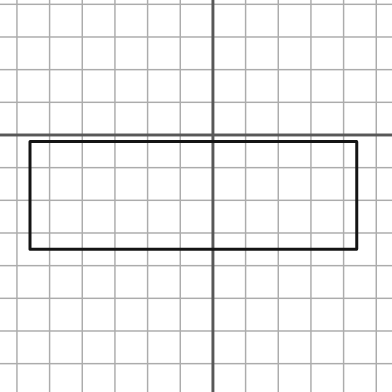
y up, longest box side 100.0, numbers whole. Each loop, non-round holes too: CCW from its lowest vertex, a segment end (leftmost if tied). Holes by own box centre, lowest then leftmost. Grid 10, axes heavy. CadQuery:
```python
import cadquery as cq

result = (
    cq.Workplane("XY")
    .moveTo(-56.0, -35.0)
    .lineTo(44.0, -35.0)
    .lineTo(44.0, -2.0)
    .lineTo(-56.0, -2.0)
    .close()
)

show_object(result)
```